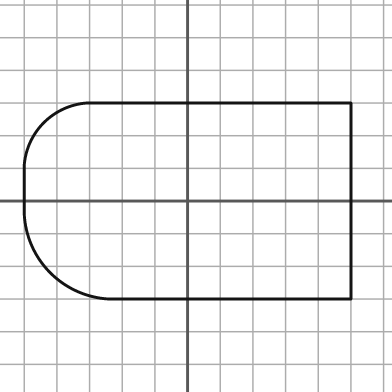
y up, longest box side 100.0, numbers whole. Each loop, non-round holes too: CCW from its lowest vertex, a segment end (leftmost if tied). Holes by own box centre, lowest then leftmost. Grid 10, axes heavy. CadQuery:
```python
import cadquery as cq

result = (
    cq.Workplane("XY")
    .moveTo(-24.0, -30.0)
    .lineTo(50.0, -30.0)
    .lineTo(50.0, 30.0)
    .lineTo(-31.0, 30.0)
    .threePointArc((-44.0, 24.0), (-50.0, 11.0))
    .lineTo(-50.0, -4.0)
    .threePointArc((-42.0, -22.0), (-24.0, -30.0))
    .close()
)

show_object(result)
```